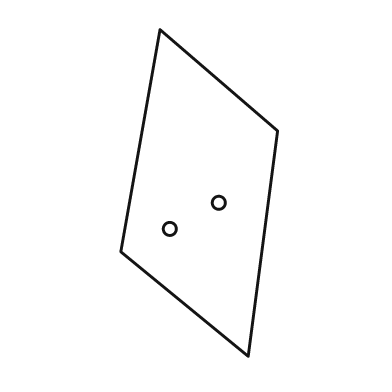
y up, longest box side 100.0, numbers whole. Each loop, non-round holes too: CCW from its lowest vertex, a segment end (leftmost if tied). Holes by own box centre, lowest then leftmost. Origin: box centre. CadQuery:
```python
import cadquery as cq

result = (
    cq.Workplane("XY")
    .moveTo(15.0, -50.0)
    .lineTo(24.0, 19.0)
    .lineTo(-12.0, 50.0)
    .lineTo(-24.0, -18.0)
    .close()
    .moveTo(-9.0, -11.0)
    .circle(2.0)
    .moveTo(6.0, -3.0)
    .circle(2.0)
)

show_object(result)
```